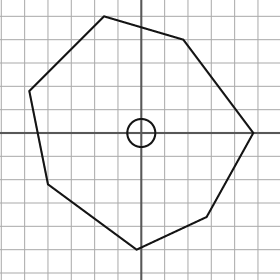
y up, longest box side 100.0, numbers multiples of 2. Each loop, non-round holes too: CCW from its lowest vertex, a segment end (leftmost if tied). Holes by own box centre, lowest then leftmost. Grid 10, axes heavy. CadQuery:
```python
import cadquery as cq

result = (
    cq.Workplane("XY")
    .moveTo(-2.0, -50.0)
    .lineTo(28.0, -36.0)
    .lineTo(48.0, 0.0)
    .lineTo(18.0, 40.0)
    .lineTo(-16.0, 50.0)
    .lineTo(-48.0, 18.0)
    .lineTo(-40.0, -22.0)
    .close()
    .moveTo(0.0, 0.0)
    .circle(6.0)
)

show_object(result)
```